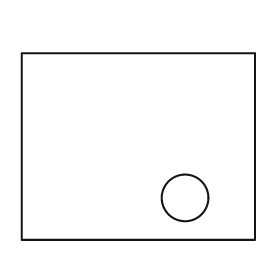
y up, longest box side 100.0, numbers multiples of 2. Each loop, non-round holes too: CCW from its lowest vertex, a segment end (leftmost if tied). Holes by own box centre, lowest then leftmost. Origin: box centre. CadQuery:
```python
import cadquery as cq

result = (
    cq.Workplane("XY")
    .moveTo(-50.0, -40.0)
    .lineTo(50.0, -40.0)
    .lineTo(50.0, 40.0)
    .lineTo(-50.0, 40.0)
    .close()
    .moveTo(20.0, -22.0)
    .circle(10.0)
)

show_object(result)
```